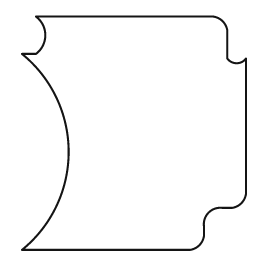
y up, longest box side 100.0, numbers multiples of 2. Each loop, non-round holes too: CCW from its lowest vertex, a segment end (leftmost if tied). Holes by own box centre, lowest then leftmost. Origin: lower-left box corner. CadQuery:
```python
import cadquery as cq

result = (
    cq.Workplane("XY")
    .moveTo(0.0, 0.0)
    .lineTo(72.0, 0.0)
    .threePointArc((76.0, 2.0), (78.0, 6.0))
    .lineTo(78.0, 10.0)
    .threePointArc((80.0, 16.0), (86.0, 18.0))
    .lineTo(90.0, 18.0)
    .threePointArc((94.0, 20.0), (96.0, 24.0))
    .lineTo(96.0, 82.0)
    .threePointArc((92.0, 80.0), (88.0, 82.0))
    .lineTo(88.0, 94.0)
    .threePointArc((86.0, 98.0), (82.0, 100.0))
    .lineTo(6.0, 100.0)
    .threePointArc((10.0, 92.0), (6.0, 84.0))
    .lineTo(0.0, 84.0)
    .threePointArc((20.0, 42.0), (0.0, 0.0))
    .close()
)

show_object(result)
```